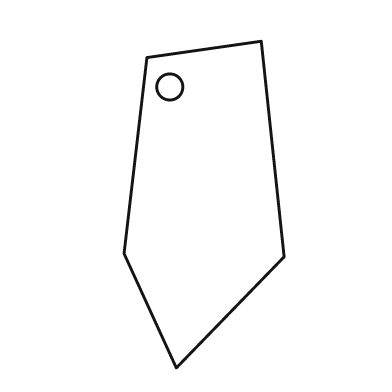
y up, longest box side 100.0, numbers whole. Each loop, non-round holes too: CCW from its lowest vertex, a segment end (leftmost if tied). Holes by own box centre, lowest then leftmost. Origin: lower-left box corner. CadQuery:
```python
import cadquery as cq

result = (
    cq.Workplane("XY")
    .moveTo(16.0, 0.0)
    .lineTo(49.0, 34.0)
    .lineTo(42.0, 100.0)
    .lineTo(7.0, 95.0)
    .lineTo(0.0, 35.0)
    .close()
    .moveTo(14.0, 86.0)
    .circle(4.0)
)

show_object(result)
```